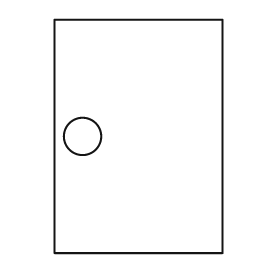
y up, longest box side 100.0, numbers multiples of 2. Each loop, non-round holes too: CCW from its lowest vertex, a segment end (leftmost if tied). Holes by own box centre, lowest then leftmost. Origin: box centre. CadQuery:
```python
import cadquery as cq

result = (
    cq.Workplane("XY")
    .moveTo(-36.0, -50.0)
    .lineTo(36.0, -50.0)
    .lineTo(36.0, 50.0)
    .lineTo(-36.0, 50.0)
    .close()
    .moveTo(-24.0, 0.0)
    .circle(8.0)
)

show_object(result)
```